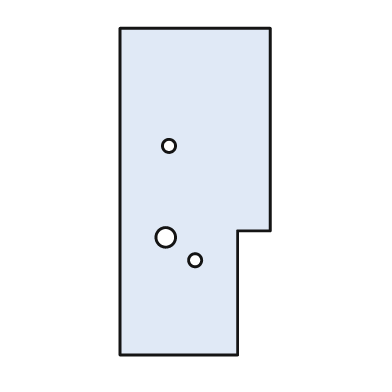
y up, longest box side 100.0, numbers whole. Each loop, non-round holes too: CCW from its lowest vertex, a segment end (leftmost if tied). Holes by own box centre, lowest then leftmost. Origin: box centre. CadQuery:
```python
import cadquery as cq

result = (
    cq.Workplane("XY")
    .moveTo(-23.0, -50.0)
    .lineTo(13.0, -50.0)
    .lineTo(13.0, -12.0)
    .lineTo(23.0, -12.0)
    .lineTo(23.0, 50.0)
    .lineTo(-23.0, 50.0)
    .close()
    .moveTo(0.0, -21.0)
    .circle(2.0)
    .moveTo(-9.0, -14.0)
    .circle(3.0)
    .moveTo(-8.0, 14.0)
    .circle(2.0)
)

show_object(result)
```